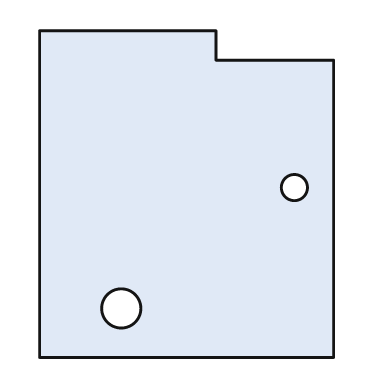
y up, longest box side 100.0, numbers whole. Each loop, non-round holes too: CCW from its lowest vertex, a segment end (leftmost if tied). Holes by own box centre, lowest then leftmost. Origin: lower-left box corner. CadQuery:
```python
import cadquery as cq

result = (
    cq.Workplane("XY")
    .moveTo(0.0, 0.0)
    .lineTo(90.0, 0.0)
    .lineTo(90.0, 91.0)
    .lineTo(54.0, 91.0)
    .lineTo(54.0, 100.0)
    .lineTo(0.0, 100.0)
    .close()
    .moveTo(25.0, 15.0)
    .circle(6.0)
    .moveTo(78.0, 52.0)
    .circle(4.0)
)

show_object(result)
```